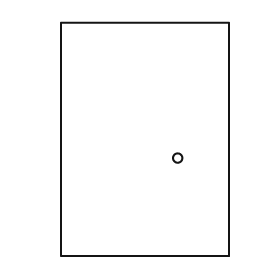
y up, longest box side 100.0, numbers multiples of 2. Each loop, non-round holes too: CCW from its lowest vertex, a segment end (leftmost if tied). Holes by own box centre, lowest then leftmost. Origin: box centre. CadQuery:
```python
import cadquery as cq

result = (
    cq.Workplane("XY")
    .moveTo(-36.0, -50.0)
    .lineTo(36.0, -50.0)
    .lineTo(36.0, 50.0)
    .lineTo(-36.0, 50.0)
    .close()
    .moveTo(14.0, -8.0)
    .circle(2.0)
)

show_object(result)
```